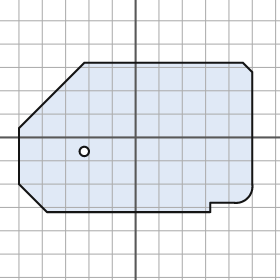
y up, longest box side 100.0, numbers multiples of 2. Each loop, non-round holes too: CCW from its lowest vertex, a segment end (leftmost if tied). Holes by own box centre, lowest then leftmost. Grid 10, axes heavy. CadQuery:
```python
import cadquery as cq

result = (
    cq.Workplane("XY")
    .moveTo(-38.0, -32.0)
    .lineTo(32.0, -32.0)
    .lineTo(32.0, -28.0)
    .lineTo(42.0, -28.0)
    .threePointArc((48.0, -26.0), (50.0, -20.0))
    .lineTo(50.0, 28.0)
    .lineTo(46.0, 32.0)
    .lineTo(-22.0, 32.0)
    .lineTo(-50.0, 4.0)
    .lineTo(-50.0, -20.0)
    .close()
    .moveTo(-22.0, -6.0)
    .circle(2.0)
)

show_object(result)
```